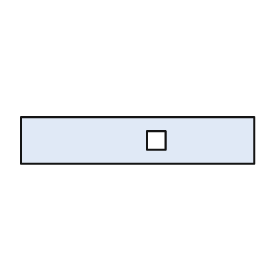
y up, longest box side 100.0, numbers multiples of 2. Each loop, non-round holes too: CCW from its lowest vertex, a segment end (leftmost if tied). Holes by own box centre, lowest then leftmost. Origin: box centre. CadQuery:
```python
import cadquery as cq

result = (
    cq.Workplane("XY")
    .moveTo(-50.0, -10.0)
    .lineTo(50.0, -10.0)
    .lineTo(50.0, 10.0)
    .lineTo(-50.0, 10.0)
    .close()
    .moveTo(4.0, -4.0)
    .lineTo(12.0, -4.0)
    .lineTo(12.0, 4.0)
    .lineTo(4.0, 4.0)
    .close()
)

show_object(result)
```